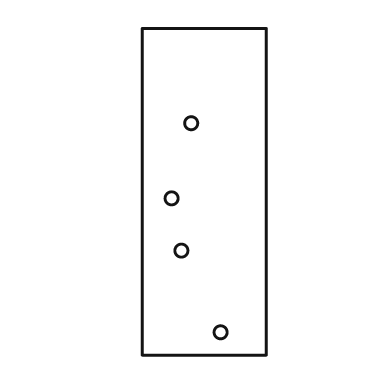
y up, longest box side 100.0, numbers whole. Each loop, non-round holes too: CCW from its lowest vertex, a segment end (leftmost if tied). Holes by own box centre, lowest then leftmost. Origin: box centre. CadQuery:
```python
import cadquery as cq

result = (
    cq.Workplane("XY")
    .moveTo(-19.0, -50.0)
    .lineTo(19.0, -50.0)
    .lineTo(19.0, 50.0)
    .lineTo(-19.0, 50.0)
    .close()
    .moveTo(5.0, -43.0)
    .circle(2.0)
    .moveTo(-7.0, -18.0)
    .circle(2.0)
    .moveTo(-10.0, -2.0)
    .circle(2.0)
    .moveTo(-4.0, 21.0)
    .circle(2.0)
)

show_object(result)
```